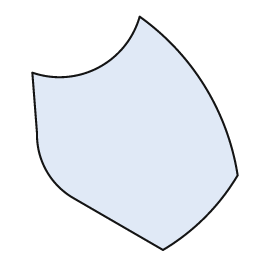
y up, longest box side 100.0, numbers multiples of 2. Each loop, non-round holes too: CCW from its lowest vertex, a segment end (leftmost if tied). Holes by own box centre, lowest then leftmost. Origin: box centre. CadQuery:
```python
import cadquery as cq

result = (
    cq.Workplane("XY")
    .moveTo(12.0, -50.0)
    .threePointArc((30.0, -36.0), (44.0, -18.0))
    .threePointArc((30.0, 20.0), (2.0, 50.0))
    .threePointArc((-16.0, 28.0), (-44.0, 26.0))
    .lineTo(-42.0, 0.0)
    .threePointArc((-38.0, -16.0), (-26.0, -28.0))
    .close()
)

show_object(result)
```